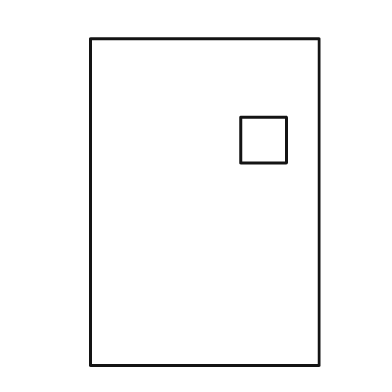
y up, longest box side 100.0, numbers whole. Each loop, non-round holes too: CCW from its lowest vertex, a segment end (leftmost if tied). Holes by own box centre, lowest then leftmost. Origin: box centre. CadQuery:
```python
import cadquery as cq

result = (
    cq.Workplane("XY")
    .moveTo(-35.0, -50.0)
    .lineTo(35.0, -50.0)
    .lineTo(35.0, 50.0)
    .lineTo(-35.0, 50.0)
    .close()
    .moveTo(11.0, 12.0)
    .lineTo(25.0, 12.0)
    .lineTo(25.0, 26.0)
    .lineTo(11.0, 26.0)
    .close()
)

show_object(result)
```